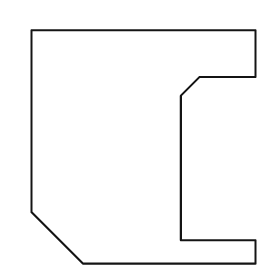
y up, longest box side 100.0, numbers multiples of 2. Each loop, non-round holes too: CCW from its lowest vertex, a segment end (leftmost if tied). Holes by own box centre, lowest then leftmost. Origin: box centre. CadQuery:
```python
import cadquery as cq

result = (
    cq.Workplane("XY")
    .moveTo(-26.0, -50.0)
    .lineTo(48.0, -50.0)
    .lineTo(48.0, -40.0)
    .lineTo(16.0, -40.0)
    .lineTo(16.0, 22.0)
    .lineTo(24.0, 30.0)
    .lineTo(48.0, 30.0)
    .lineTo(48.0, 50.0)
    .lineTo(-48.0, 50.0)
    .lineTo(-48.0, -28.0)
    .close()
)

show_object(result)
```